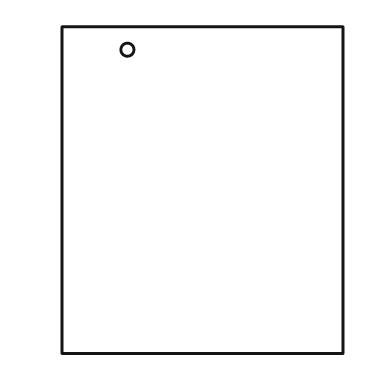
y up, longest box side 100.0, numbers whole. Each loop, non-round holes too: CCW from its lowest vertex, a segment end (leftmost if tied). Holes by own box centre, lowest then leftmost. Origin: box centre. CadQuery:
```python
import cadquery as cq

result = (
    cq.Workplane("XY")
    .moveTo(-43.0, -50.0)
    .lineTo(43.0, -50.0)
    .lineTo(43.0, 50.0)
    .lineTo(-43.0, 50.0)
    .close()
    .moveTo(-23.0, 43.0)
    .circle(2.0)
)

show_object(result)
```